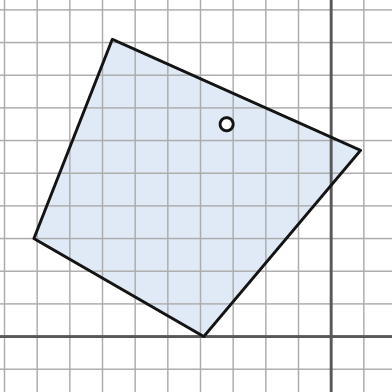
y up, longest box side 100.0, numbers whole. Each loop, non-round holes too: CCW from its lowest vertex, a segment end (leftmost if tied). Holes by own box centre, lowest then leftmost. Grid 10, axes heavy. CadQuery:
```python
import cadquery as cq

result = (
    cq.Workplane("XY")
    .moveTo(-39.0, 0.0)
    .lineTo(9.0, 57.0)
    .lineTo(-67.0, 91.0)
    .lineTo(-91.0, 30.0)
    .close()
    .moveTo(-32.0, 65.0)
    .circle(2.0)
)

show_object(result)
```